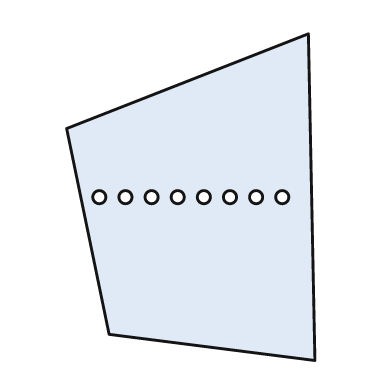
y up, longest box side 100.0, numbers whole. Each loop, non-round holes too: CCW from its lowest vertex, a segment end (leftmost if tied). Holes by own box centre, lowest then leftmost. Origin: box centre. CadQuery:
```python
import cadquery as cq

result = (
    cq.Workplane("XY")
    .moveTo(38.0, -50.0)
    .lineTo(36.0, 50.0)
    .lineTo(-38.0, 21.0)
    .lineTo(-25.0, -42.0)
    .close()
    .moveTo(-28.0, 0.0)
    .circle(2.0)
    .moveTo(-20.0, 0.0)
    .circle(2.0)
    .moveTo(-12.0, 0.0)
    .circle(2.0)
    .moveTo(-4.0, 0.0)
    .circle(2.0)
    .moveTo(4.0, 0.0)
    .circle(2.0)
    .moveTo(12.0, 0.0)
    .circle(2.0)
    .moveTo(20.0, 0.0)
    .circle(2.0)
    .moveTo(28.0, 0.0)
    .circle(2.0)
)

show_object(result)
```